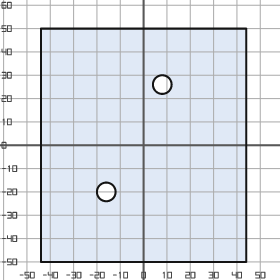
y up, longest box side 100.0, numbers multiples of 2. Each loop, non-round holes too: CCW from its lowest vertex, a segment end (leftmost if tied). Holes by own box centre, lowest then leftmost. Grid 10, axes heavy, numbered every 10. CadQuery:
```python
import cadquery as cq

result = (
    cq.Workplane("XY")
    .moveTo(-44.0, -50.0)
    .lineTo(44.0, -50.0)
    .lineTo(44.0, 50.0)
    .lineTo(-44.0, 50.0)
    .close()
    .moveTo(-16.0, -20.0)
    .circle(4.0)
    .moveTo(8.0, 26.0)
    .circle(4.0)
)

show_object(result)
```